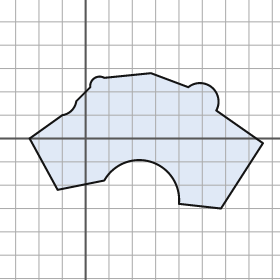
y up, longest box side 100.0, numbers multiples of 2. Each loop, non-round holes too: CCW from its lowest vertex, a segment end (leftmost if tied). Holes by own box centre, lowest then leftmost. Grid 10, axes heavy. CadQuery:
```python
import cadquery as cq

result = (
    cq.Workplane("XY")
    .moveTo(58.0, -30.0)
    .lineTo(76.0, -2.0)
    .lineTo(56.0, 12.0)
    .threePointArc((54.0, 22.0), (44.0, 22.0))
    .lineTo(28.0, 28.0)
    .lineTo(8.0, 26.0)
    .threePointArc((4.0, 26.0), (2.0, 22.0))
    .lineTo(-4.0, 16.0)
    .threePointArc((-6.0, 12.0), (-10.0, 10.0))
    .lineTo(-24.0, 0.0)
    .lineTo(-12.0, -22.0)
    .lineTo(8.0, -18.0)
    .threePointArc((28.0, -10.0), (40.0, -28.0))
    .close()
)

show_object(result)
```